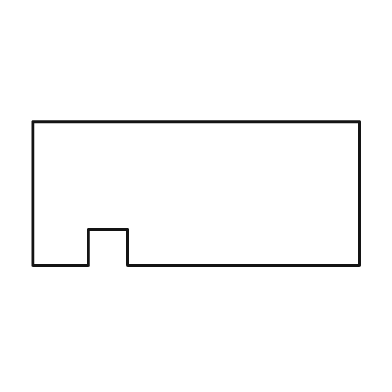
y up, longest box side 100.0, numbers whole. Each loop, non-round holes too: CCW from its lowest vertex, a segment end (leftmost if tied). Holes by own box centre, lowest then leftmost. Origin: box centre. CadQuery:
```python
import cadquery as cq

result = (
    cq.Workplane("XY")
    .moveTo(-50.0, -22.0)
    .lineTo(-33.0, -22.0)
    .lineTo(-33.0, -11.0)
    .lineTo(-21.0, -11.0)
    .lineTo(-21.0, -22.0)
    .lineTo(50.0, -22.0)
    .lineTo(50.0, 22.0)
    .lineTo(-50.0, 22.0)
    .close()
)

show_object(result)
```